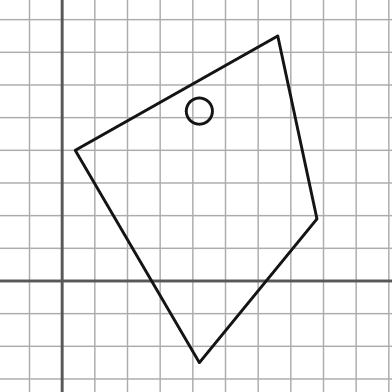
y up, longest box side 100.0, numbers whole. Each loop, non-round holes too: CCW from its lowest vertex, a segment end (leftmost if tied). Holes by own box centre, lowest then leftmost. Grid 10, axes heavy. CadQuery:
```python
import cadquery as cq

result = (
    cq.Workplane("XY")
    .moveTo(42.0, -25.0)
    .lineTo(78.0, 19.0)
    .lineTo(66.0, 75.0)
    .lineTo(4.0, 40.0)
    .close()
    .moveTo(42.0, 52.0)
    .circle(4.0)
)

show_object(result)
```